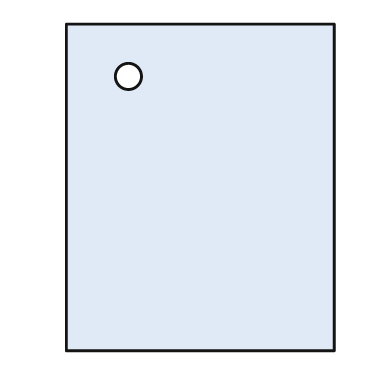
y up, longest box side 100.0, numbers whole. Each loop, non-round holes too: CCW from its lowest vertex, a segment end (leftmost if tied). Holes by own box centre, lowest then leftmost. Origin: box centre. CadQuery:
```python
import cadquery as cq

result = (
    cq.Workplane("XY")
    .moveTo(-41.0, -50.0)
    .lineTo(41.0, -50.0)
    .lineTo(41.0, 50.0)
    .lineTo(-41.0, 50.0)
    .close()
    .moveTo(-22.0, 34.0)
    .circle(4.0)
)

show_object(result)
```